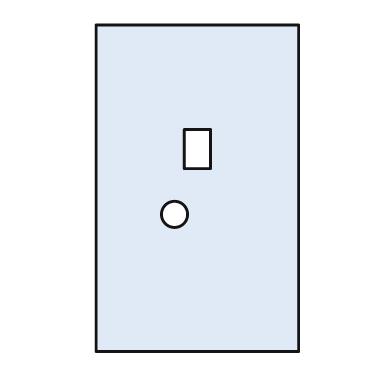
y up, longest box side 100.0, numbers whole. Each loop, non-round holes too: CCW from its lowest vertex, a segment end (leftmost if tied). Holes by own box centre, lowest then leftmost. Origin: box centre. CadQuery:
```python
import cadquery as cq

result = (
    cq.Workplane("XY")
    .moveTo(-31.0, -50.0)
    .lineTo(31.0, -50.0)
    .lineTo(31.0, 50.0)
    .lineTo(-31.0, 50.0)
    .close()
    .moveTo(-7.0, -8.0)
    .circle(4.0)
    .moveTo(-4.0, 6.0)
    .lineTo(4.0, 6.0)
    .lineTo(4.0, 18.0)
    .lineTo(-4.0, 18.0)
    .close()
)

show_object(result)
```